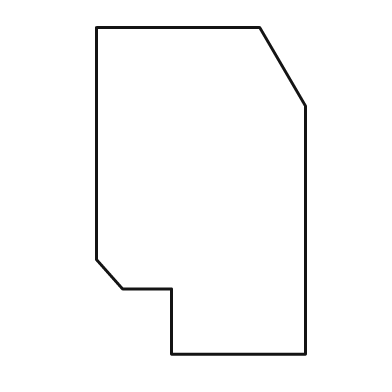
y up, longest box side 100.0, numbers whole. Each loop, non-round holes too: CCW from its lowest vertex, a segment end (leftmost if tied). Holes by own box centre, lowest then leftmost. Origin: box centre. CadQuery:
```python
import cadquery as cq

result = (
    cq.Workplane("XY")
    .moveTo(-9.0, -50.0)
    .lineTo(32.0, -50.0)
    .lineTo(32.0, 26.0)
    .lineTo(18.0, 50.0)
    .lineTo(-32.0, 50.0)
    .lineTo(-32.0, -21.0)
    .lineTo(-24.0, -30.0)
    .lineTo(-9.0, -30.0)
    .close()
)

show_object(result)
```